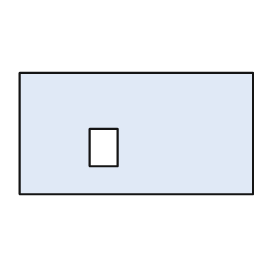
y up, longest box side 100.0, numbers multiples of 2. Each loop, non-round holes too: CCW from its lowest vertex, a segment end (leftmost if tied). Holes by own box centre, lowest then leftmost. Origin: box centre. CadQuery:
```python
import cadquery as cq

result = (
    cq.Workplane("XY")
    .moveTo(-50.0, -26.0)
    .lineTo(50.0, -26.0)
    .lineTo(50.0, 26.0)
    .lineTo(-50.0, 26.0)
    .close()
    .moveTo(-20.0, -14.0)
    .lineTo(-8.0, -14.0)
    .lineTo(-8.0, 2.0)
    .lineTo(-20.0, 2.0)
    .close()
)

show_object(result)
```